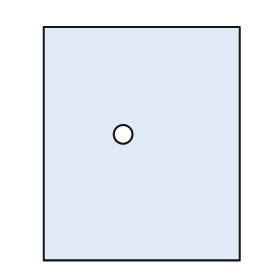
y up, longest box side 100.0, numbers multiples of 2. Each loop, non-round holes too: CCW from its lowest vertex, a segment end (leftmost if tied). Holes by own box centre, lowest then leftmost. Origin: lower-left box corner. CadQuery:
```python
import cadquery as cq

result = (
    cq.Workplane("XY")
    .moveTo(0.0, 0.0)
    .lineTo(84.0, 0.0)
    .lineTo(84.0, 100.0)
    .lineTo(0.0, 100.0)
    .close()
    .moveTo(34.0, 54.0)
    .circle(4.0)
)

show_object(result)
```